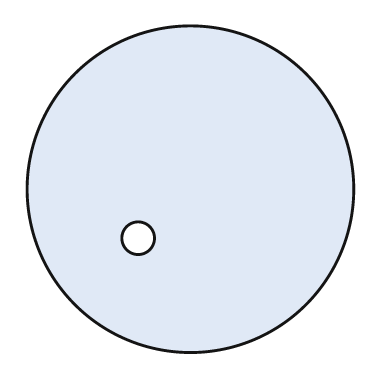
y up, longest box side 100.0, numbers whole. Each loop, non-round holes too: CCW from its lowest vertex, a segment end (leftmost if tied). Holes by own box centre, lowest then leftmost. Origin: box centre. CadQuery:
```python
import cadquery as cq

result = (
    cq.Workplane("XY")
    .moveTo(0.0, 0.0)
    .circle(50.0)
    .moveTo(-16.0, -15.0)
    .circle(5.0)
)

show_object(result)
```